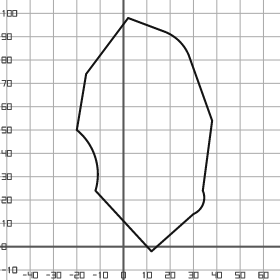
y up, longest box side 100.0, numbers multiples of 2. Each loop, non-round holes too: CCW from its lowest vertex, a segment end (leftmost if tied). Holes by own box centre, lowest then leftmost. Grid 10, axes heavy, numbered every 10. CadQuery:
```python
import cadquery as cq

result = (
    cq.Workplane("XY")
    .moveTo(12.0, -2.0)
    .lineTo(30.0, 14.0)
    .threePointArc((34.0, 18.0), (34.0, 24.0))
    .lineTo(38.0, 54.0)
    .lineTo(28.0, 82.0)
    .threePointArc((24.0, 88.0), (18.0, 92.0))
    .lineTo(2.0, 98.0)
    .lineTo(-16.0, 74.0)
    .lineTo(-20.0, 50.0)
    .threePointArc((-12.0, 38.0), (-12.0, 24.0))
    .close()
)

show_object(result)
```